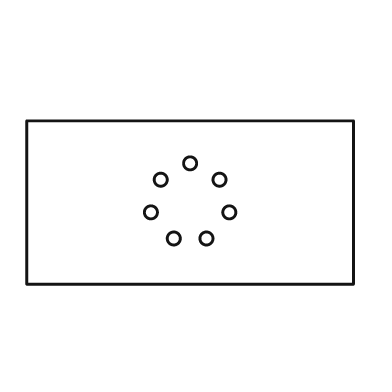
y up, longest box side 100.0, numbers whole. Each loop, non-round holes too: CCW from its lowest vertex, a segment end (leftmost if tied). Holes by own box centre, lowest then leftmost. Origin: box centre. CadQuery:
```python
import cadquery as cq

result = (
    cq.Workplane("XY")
    .moveTo(-50.0, -25.0)
    .lineTo(50.0, -25.0)
    .lineTo(50.0, 25.0)
    .lineTo(-50.0, 25.0)
    .close()
    .moveTo(-5.0, -11.0)
    .circle(2.0)
    .moveTo(5.0, -11.0)
    .circle(2.0)
    .moveTo(-12.0, -3.0)
    .circle(2.0)
    .moveTo(12.0, -3.0)
    .circle(2.0)
    .moveTo(-9.0, 7.0)
    .circle(2.0)
    .moveTo(9.0, 7.0)
    .circle(2.0)
    .moveTo(0.0, 12.0)
    .circle(2.0)
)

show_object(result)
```